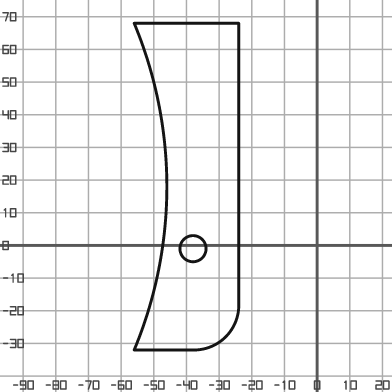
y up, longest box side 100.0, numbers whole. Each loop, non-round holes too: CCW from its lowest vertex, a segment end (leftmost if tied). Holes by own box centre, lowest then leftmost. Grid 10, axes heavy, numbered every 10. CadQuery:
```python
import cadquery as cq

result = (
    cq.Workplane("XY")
    .moveTo(-56.0, -32.0)
    .lineTo(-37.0, -32.0)
    .threePointArc((-28.0, -28.0), (-24.0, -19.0))
    .lineTo(-24.0, 68.0)
    .lineTo(-56.0, 68.0)
    .threePointArc((-46.0, 18.0), (-56.0, -32.0))
    .close()
    .moveTo(-38.0, -1.0)
    .circle(4.0)
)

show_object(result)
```